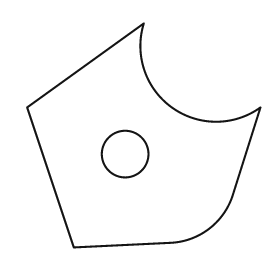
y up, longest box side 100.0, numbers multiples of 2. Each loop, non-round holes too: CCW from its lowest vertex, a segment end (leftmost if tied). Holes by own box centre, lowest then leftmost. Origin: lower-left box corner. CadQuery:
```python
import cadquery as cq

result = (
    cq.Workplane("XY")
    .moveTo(20.0, 0.0)
    .lineTo(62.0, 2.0)
    .threePointArc((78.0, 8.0), (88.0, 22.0))
    .lineTo(100.0, 60.0)
    .threePointArc((62.0, 60.0), (50.0, 96.0))
    .lineTo(0.0, 60.0)
    .close()
    .moveTo(42.0, 40.0)
    .circle(10.0)
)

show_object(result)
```